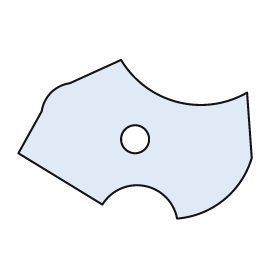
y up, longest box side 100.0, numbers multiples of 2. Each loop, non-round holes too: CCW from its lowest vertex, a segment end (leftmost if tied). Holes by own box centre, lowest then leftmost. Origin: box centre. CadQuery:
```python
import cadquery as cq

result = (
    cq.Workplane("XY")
    .moveTo(18.0, -34.0)
    .threePointArc((38.0, -26.0), (50.0, -8.0))
    .lineTo(48.0, 20.0)
    .threePointArc((18.0, 16.0), (-6.0, 34.0))
    .lineTo(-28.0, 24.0)
    .threePointArc((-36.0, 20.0), (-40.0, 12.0))
    .lineTo(-50.0, -6.0)
    .lineTo(-14.0, -28.0)
    .threePointArc((4.0, -20.0), (18.0, -34.0))
    .close()
    .moveTo(0.0, 0.0)
    .circle(6.0)
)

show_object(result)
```